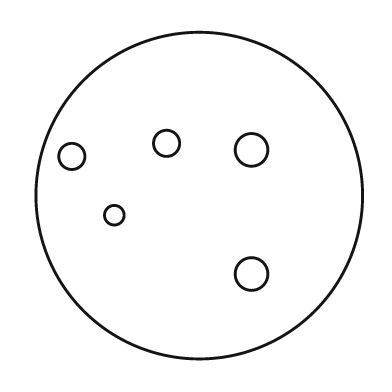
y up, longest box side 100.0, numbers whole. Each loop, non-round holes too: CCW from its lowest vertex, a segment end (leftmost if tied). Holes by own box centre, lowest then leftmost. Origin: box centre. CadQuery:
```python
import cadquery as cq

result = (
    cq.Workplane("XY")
    .moveTo(0.0, 0.0)
    .circle(50.0)
    .moveTo(16.0, -24.0)
    .circle(5.0)
    .moveTo(-26.0, -6.0)
    .circle(3.0)
    .moveTo(-39.0, 12.0)
    .circle(4.0)
    .moveTo(16.0, 14.0)
    .circle(5.0)
    .moveTo(-10.0, 16.0)
    .circle(4.0)
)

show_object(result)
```